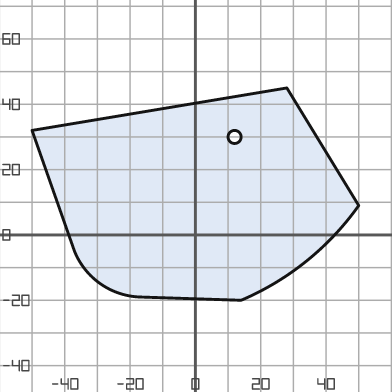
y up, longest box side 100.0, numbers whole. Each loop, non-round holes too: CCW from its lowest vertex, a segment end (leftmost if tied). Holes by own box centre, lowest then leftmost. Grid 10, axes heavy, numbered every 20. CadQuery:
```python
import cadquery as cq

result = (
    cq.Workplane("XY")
    .moveTo(14.0, -20.0)
    .threePointArc((34.0, -8.0), (50.0, 9.0))
    .lineTo(28.0, 45.0)
    .lineTo(-50.0, 32.0)
    .lineTo(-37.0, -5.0)
    .threePointArc((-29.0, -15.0), (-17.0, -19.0))
    .close()
    .moveTo(12.0, 30.0)
    .circle(2.0)
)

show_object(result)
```